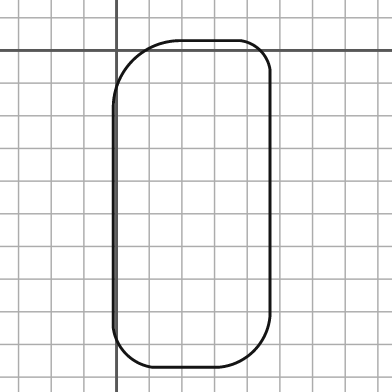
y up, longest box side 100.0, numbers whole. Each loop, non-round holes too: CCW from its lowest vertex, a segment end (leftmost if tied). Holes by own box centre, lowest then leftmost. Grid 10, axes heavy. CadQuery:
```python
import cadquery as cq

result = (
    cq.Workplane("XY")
    .moveTo(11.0, -97.0)
    .lineTo(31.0, -97.0)
    .threePointArc((42.0, -92.0), (47.0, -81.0))
    .lineTo(47.0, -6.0)
    .threePointArc((44.0, 0.0), (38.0, 3.0))
    .lineTo(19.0, 3.0)
    .threePointArc((5.0, -3.0), (-1.0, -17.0))
    .lineTo(-1.0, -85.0)
    .threePointArc((3.0, -93.0), (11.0, -97.0))
    .close()
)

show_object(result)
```